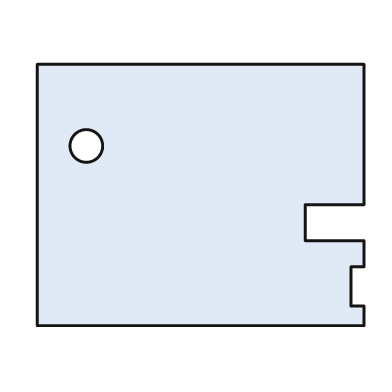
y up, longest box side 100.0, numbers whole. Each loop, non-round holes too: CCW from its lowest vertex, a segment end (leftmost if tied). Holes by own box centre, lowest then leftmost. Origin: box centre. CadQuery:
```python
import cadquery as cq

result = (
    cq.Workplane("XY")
    .moveTo(-50.0, -40.0)
    .lineTo(50.0, -40.0)
    .lineTo(50.0, -34.0)
    .lineTo(46.0, -34.0)
    .lineTo(46.0, -22.0)
    .lineTo(50.0, -22.0)
    .lineTo(50.0, -14.0)
    .lineTo(32.0, -14.0)
    .lineTo(32.0, -3.0)
    .lineTo(50.0, -3.0)
    .lineTo(50.0, 40.0)
    .lineTo(-50.0, 40.0)
    .close()
    .moveTo(-35.0, 15.0)
    .circle(5.0)
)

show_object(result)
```